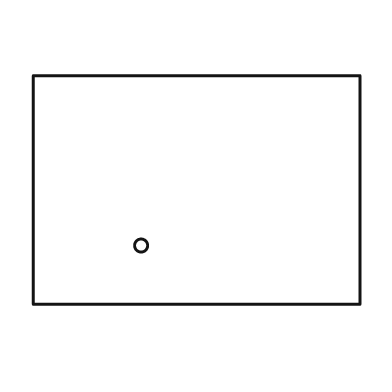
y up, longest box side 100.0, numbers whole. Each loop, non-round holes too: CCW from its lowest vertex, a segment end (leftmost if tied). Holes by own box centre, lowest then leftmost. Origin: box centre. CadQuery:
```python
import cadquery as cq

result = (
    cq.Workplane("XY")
    .moveTo(-50.0, -35.0)
    .lineTo(50.0, -35.0)
    .lineTo(50.0, 35.0)
    .lineTo(-50.0, 35.0)
    .close()
    .moveTo(-17.0, -17.0)
    .circle(2.0)
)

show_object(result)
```